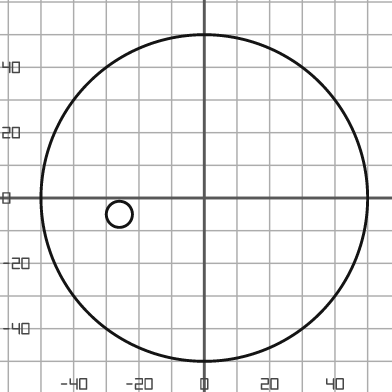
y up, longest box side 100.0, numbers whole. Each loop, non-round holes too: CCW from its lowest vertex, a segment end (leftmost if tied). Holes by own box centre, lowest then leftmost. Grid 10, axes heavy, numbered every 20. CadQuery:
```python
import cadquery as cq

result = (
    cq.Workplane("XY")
    .moveTo(0.0, 0.0)
    .circle(50.0)
    .moveTo(-26.0, -5.0)
    .circle(4.0)
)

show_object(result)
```